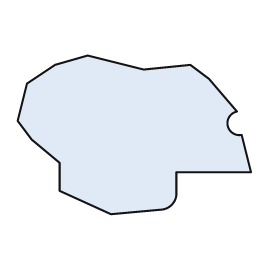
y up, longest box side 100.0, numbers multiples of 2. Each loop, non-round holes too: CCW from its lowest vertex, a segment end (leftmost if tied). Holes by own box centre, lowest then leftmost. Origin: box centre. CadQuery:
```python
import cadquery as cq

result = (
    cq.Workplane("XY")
    .moveTo(-10.0, -34.0)
    .lineTo(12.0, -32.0)
    .threePointArc((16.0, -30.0), (18.0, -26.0))
    .lineTo(18.0, -16.0)
    .lineTo(50.0, -16.0)
    .lineTo(46.0, 0.0)
    .threePointArc((40.0, 4.0), (44.0, 10.0))
    .lineTo(32.0, 24.0)
    .lineTo(24.0, 30.0)
    .lineTo(4.0, 28.0)
    .lineTo(-20.0, 34.0)
    .lineTo(-34.0, 30.0)
    .lineTo(-46.0, 22.0)
    .lineTo(-50.0, 6.0)
    .lineTo(-44.0, -2.0)
    .lineTo(-32.0, -12.0)
    .lineTo(-32.0, -24.0)
    .close()
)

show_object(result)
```